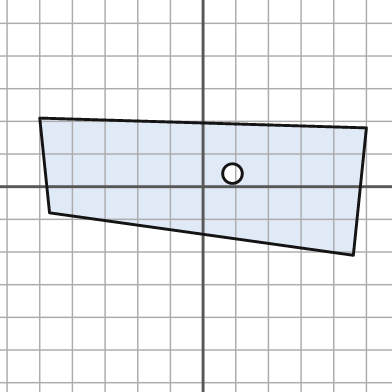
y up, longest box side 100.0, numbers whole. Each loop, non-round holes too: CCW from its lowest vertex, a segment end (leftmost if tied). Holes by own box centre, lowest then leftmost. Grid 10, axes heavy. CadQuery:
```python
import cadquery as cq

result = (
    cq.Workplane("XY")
    .moveTo(46.0, -21.0)
    .lineTo(50.0, 18.0)
    .lineTo(-50.0, 21.0)
    .lineTo(-47.0, -8.0)
    .close()
    .moveTo(9.0, 4.0)
    .circle(3.0)
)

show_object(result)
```